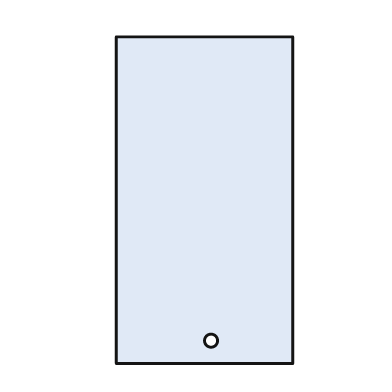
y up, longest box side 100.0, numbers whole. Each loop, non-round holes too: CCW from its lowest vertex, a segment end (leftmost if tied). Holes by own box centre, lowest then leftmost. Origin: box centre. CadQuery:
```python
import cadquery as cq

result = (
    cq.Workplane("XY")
    .moveTo(-27.0, -50.0)
    .lineTo(27.0, -50.0)
    .lineTo(27.0, 50.0)
    .lineTo(-27.0, 50.0)
    .close()
    .moveTo(2.0, -43.0)
    .circle(2.0)
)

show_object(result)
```